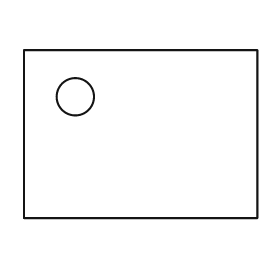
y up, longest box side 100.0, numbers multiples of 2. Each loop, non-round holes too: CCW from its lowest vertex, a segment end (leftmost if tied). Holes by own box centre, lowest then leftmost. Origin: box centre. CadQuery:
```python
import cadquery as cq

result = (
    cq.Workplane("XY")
    .moveTo(-50.0, -36.0)
    .lineTo(50.0, -36.0)
    .lineTo(50.0, 36.0)
    .lineTo(-50.0, 36.0)
    .close()
    .moveTo(-28.0, 16.0)
    .circle(8.0)
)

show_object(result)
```